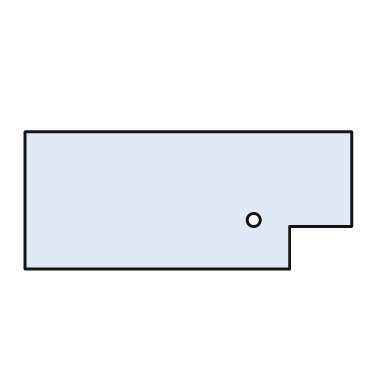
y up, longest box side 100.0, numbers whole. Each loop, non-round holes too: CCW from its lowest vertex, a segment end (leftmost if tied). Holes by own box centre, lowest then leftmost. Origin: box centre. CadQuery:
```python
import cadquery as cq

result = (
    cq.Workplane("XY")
    .moveTo(-50.0, -21.0)
    .lineTo(31.0, -21.0)
    .lineTo(31.0, -8.0)
    .lineTo(50.0, -8.0)
    .lineTo(50.0, 21.0)
    .lineTo(-50.0, 21.0)
    .close()
    .moveTo(20.0, -6.0)
    .circle(2.0)
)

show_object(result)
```